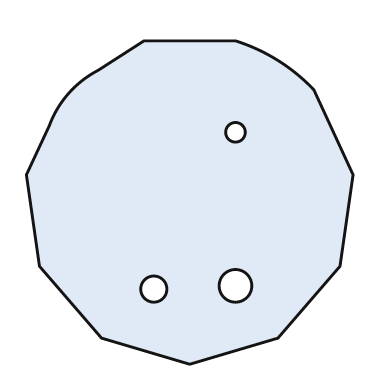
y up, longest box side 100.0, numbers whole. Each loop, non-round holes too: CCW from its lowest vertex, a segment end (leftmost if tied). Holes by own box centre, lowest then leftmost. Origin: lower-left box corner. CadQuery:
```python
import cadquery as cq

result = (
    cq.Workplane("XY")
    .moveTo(50.0, 0.0)
    .lineTo(77.0, 8.0)
    .lineTo(96.0, 30.0)
    .lineTo(100.0, 58.0)
    .lineTo(88.0, 84.0)
    .threePointArc((77.0, 93.0), (64.0, 99.0))
    .lineTo(36.0, 99.0)
    .lineTo(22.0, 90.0)
    .threePointArc((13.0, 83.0), (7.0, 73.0))
    .lineTo(0.0, 58.0)
    .lineTo(4.0, 30.0)
    .lineTo(23.0, 8.0)
    .close()
    .moveTo(39.0, 23.0)
    .circle(4.0)
    .moveTo(64.0, 24.0)
    .circle(5.0)
    .moveTo(64.0, 71.0)
    .circle(3.0)
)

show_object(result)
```